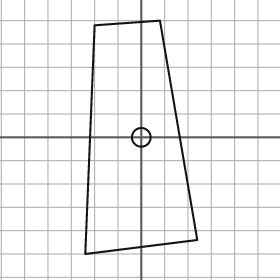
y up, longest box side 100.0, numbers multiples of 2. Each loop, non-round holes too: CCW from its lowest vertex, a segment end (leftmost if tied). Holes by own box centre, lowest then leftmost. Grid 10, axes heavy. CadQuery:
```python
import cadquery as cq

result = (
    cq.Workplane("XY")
    .moveTo(-24.0, -50.0)
    .lineTo(24.0, -44.0)
    .lineTo(8.0, 50.0)
    .lineTo(-20.0, 48.0)
    .close()
    .moveTo(0.0, 0.0)
    .circle(4.0)
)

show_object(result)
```